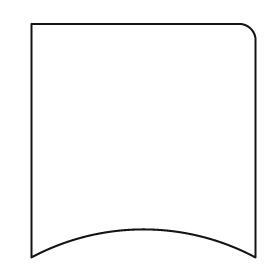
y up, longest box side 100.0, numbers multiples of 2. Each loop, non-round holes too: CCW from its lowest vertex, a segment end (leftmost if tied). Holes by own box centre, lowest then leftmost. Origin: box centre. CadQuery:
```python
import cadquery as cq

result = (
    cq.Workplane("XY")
    .moveTo(-48.0, -50.0)
    .threePointArc((0.0, -38.0), (48.0, -50.0))
    .lineTo(48.0, 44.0)
    .threePointArc((46.0, 48.0), (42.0, 50.0))
    .lineTo(-48.0, 50.0)
    .close()
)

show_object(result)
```